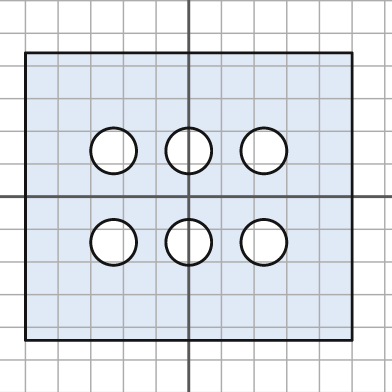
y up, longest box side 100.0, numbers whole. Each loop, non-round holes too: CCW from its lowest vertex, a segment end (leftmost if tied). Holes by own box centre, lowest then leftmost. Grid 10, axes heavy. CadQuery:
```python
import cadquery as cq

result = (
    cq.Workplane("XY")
    .moveTo(-50.0, -44.0)
    .lineTo(50.0, -44.0)
    .lineTo(50.0, 44.0)
    .lineTo(-50.0, 44.0)
    .close()
    .moveTo(-23.0, -14.0)
    .circle(7.0)
    .moveTo(0.0, -14.0)
    .circle(7.0)
    .moveTo(23.0, -14.0)
    .circle(7.0)
    .moveTo(-23.0, 14.0)
    .circle(7.0)
    .moveTo(0.0, 14.0)
    .circle(7.0)
    .moveTo(23.0, 14.0)
    .circle(7.0)
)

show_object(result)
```